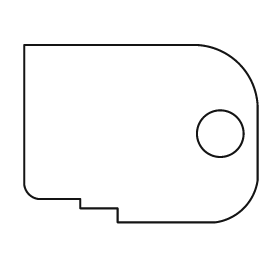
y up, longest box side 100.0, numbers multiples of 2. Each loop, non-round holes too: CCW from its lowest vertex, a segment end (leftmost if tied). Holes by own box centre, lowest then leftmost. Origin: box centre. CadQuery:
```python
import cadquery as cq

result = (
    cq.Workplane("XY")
    .moveTo(-10.0, -38.0)
    .lineTo(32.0, -38.0)
    .threePointArc((44.0, -32.0), (50.0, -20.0))
    .lineTo(50.0, 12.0)
    .threePointArc((42.0, 30.0), (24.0, 38.0))
    .lineTo(-50.0, 38.0)
    .lineTo(-50.0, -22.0)
    .threePointArc((-48.0, -26.0), (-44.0, -28.0))
    .lineTo(-26.0, -28.0)
    .lineTo(-26.0, -32.0)
    .lineTo(-10.0, -32.0)
    .close()
    .moveTo(34.0, 0.0)
    .circle(10.0)
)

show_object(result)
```